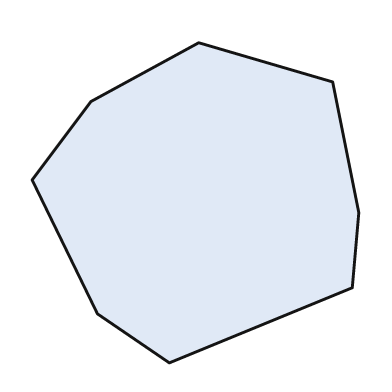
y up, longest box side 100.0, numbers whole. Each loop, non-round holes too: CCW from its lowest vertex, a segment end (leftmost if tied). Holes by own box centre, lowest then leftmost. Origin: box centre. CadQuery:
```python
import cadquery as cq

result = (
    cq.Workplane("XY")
    .moveTo(-8.0, -49.0)
    .lineTo(48.0, -26.0)
    .lineTo(50.0, -3.0)
    .lineTo(42.0, 37.0)
    .lineTo(1.0, 49.0)
    .lineTo(-32.0, 31.0)
    .lineTo(-50.0, 7.0)
    .lineTo(-30.0, -34.0)
    .close()
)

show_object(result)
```